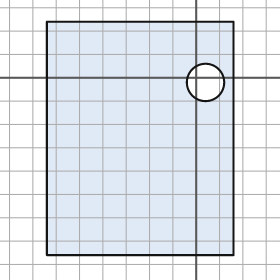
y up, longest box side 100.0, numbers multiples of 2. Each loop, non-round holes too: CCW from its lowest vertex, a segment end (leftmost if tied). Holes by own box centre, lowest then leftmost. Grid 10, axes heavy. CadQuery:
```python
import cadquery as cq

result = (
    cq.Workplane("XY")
    .moveTo(-64.0, -76.0)
    .lineTo(16.0, -76.0)
    .lineTo(16.0, 24.0)
    .lineTo(-64.0, 24.0)
    .close()
    .moveTo(4.0, -2.0)
    .circle(8.0)
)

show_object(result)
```